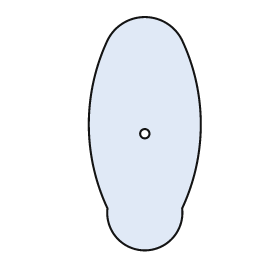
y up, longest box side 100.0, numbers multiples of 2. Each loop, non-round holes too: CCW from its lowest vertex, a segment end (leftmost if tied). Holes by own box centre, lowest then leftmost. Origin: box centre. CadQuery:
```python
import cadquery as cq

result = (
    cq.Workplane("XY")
    .moveTo(-16.0, -32.0)
    .threePointArc((0.0, -50.0), (16.0, -32.0))
    .threePointArc((24.0, 4.0), (16.0, 40.0))
    .threePointArc((0.0, 50.0), (-16.0, 40.0))
    .threePointArc((-24.0, 4.0), (-16.0, -32.0))
    .close()
    .moveTo(0.0, 0.0)
    .circle(2.0)
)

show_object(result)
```